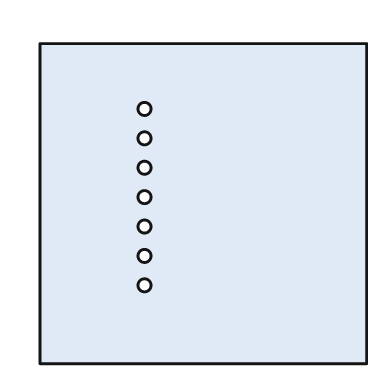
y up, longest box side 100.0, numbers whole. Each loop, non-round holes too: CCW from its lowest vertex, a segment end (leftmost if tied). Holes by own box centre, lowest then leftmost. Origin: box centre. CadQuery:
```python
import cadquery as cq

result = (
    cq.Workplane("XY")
    .moveTo(-50.0, -49.0)
    .lineTo(50.0, -49.0)
    .lineTo(50.0, 49.0)
    .lineTo(-50.0, 49.0)
    .close()
    .moveTo(-18.0, -25.0)
    .circle(2.0)
    .moveTo(-18.0, -16.0)
    .circle(2.0)
    .moveTo(-18.0, -7.0)
    .circle(2.0)
    .moveTo(-18.0, 2.0)
    .circle(2.0)
    .moveTo(-18.0, 11.0)
    .circle(2.0)
    .moveTo(-18.0, 20.0)
    .circle(2.0)
    .moveTo(-18.0, 29.0)
    .circle(2.0)
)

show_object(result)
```